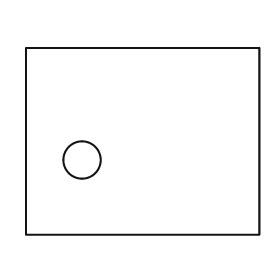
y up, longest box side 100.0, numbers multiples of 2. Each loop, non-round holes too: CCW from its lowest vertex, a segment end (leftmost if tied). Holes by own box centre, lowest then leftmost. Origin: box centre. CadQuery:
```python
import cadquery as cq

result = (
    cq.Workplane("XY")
    .moveTo(-50.0, -40.0)
    .lineTo(50.0, -40.0)
    .lineTo(50.0, 40.0)
    .lineTo(-50.0, 40.0)
    .close()
    .moveTo(-26.0, -8.0)
    .circle(8.0)
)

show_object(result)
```